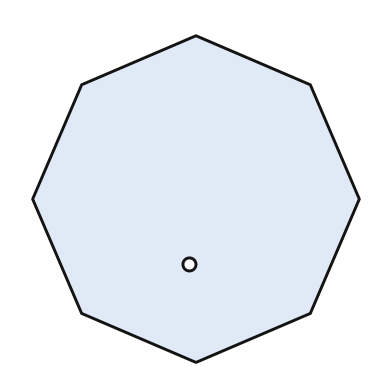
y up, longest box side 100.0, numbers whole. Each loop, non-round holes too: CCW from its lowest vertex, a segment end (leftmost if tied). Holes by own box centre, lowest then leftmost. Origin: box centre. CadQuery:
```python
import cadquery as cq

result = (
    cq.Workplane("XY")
    .moveTo(0.0, -50.0)
    .lineTo(35.0, -35.0)
    .lineTo(50.0, 0.0)
    .lineTo(35.0, 35.0)
    .lineTo(0.0, 50.0)
    .lineTo(-35.0, 35.0)
    .lineTo(-50.0, 0.0)
    .lineTo(-35.0, -35.0)
    .close()
    .moveTo(-2.0, -20.0)
    .circle(2.0)
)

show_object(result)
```